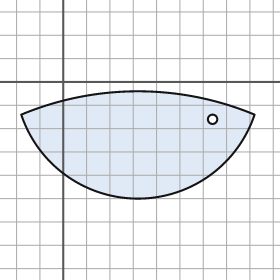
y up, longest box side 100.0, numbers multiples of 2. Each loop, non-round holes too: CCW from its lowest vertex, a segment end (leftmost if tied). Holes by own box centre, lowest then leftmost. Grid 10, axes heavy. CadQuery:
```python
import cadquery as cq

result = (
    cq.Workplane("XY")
    .moveTo(-18.0, -14.0)
    .threePointArc((32.0, -50.0), (82.0, -14.0))
    .threePointArc((32.0, -4.0), (-18.0, -14.0))
    .close()
    .moveTo(64.0, -16.0)
    .circle(2.0)
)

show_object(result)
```